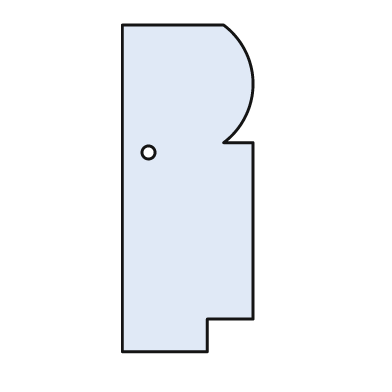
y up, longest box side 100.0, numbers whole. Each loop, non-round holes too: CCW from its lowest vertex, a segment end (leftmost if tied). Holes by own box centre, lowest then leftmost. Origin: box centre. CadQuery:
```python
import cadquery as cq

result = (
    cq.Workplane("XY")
    .moveTo(-20.0, -50.0)
    .lineTo(6.0, -50.0)
    .lineTo(6.0, -40.0)
    .lineTo(20.0, -40.0)
    .lineTo(20.0, 14.0)
    .lineTo(11.0, 14.0)
    .threePointArc((20.0, 32.0), (11.0, 50.0))
    .lineTo(-20.0, 50.0)
    .close()
    .moveTo(-12.0, 11.0)
    .circle(2.0)
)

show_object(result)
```